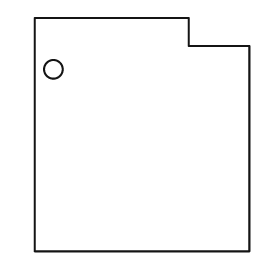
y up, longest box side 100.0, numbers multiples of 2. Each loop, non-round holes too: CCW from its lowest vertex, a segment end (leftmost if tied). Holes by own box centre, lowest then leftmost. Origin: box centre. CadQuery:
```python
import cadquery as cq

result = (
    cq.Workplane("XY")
    .moveTo(-46.0, -50.0)
    .lineTo(46.0, -50.0)
    .lineTo(46.0, 38.0)
    .lineTo(20.0, 38.0)
    .lineTo(20.0, 50.0)
    .lineTo(-46.0, 50.0)
    .close()
    .moveTo(-38.0, 28.0)
    .circle(4.0)
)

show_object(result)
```